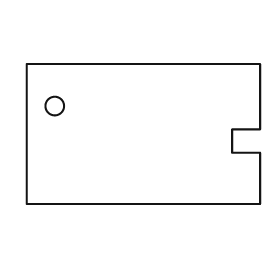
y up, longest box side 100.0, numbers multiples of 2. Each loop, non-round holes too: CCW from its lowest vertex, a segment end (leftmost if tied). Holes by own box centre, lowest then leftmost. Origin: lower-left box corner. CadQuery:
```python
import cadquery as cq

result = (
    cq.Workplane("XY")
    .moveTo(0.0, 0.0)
    .lineTo(100.0, 0.0)
    .lineTo(100.0, 22.0)
    .lineTo(88.0, 22.0)
    .lineTo(88.0, 32.0)
    .lineTo(100.0, 32.0)
    .lineTo(100.0, 60.0)
    .lineTo(0.0, 60.0)
    .close()
    .moveTo(12.0, 42.0)
    .circle(4.0)
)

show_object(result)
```